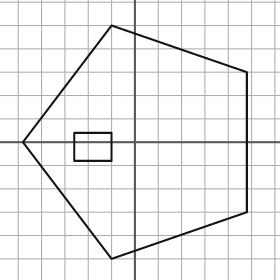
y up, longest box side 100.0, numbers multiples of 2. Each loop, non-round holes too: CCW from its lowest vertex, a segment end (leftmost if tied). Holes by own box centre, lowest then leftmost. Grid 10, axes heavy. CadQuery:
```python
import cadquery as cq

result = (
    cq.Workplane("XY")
    .moveTo(-10.0, -50.0)
    .lineTo(48.0, -30.0)
    .lineTo(48.0, 30.0)
    .lineTo(-10.0, 50.0)
    .lineTo(-48.0, 0.0)
    .close()
    .moveTo(-26.0, -8.0)
    .lineTo(-10.0, -8.0)
    .lineTo(-10.0, 4.0)
    .lineTo(-26.0, 4.0)
    .close()
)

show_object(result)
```